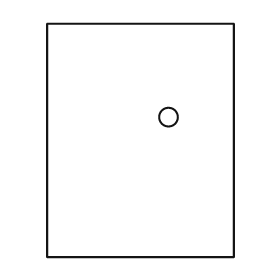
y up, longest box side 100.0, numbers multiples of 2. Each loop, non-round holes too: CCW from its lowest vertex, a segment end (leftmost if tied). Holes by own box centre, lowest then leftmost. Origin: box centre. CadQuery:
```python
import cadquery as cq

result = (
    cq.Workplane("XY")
    .moveTo(-40.0, -50.0)
    .lineTo(40.0, -50.0)
    .lineTo(40.0, 50.0)
    .lineTo(-40.0, 50.0)
    .close()
    .moveTo(12.0, 10.0)
    .circle(4.0)
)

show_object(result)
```